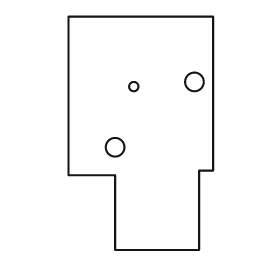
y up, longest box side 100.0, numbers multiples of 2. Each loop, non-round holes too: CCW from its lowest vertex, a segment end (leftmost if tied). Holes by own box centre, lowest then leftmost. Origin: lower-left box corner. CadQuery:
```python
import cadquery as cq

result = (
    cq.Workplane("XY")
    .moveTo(20.0, 0.0)
    .lineTo(56.0, 0.0)
    .lineTo(56.0, 34.0)
    .lineTo(62.0, 34.0)
    .lineTo(62.0, 100.0)
    .lineTo(0.0, 100.0)
    .lineTo(0.0, 32.0)
    .lineTo(20.0, 32.0)
    .close()
    .moveTo(20.0, 44.0)
    .circle(4.0)
    .moveTo(28.0, 70.0)
    .circle(2.0)
    .moveTo(54.0, 72.0)
    .circle(4.0)
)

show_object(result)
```